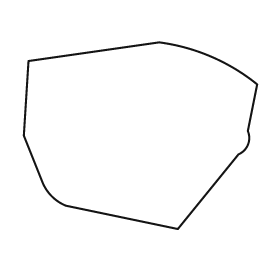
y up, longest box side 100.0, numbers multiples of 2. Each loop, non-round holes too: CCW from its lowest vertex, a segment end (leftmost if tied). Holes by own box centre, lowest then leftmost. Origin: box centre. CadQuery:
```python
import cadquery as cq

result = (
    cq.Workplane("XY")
    .moveTo(16.0, -40.0)
    .lineTo(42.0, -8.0)
    .threePointArc((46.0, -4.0), (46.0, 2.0))
    .lineTo(50.0, 22.0)
    .threePointArc((30.0, 34.0), (8.0, 40.0))
    .lineTo(-48.0, 32.0)
    .lineTo(-50.0, 0.0)
    .lineTo(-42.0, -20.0)
    .threePointArc((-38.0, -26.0), (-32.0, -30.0))
    .close()
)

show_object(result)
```